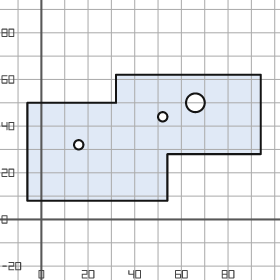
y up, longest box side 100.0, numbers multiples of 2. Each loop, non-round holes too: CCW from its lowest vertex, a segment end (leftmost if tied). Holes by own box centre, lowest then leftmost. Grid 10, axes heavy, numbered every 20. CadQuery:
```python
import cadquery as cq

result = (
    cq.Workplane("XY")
    .moveTo(-6.0, 8.0)
    .lineTo(54.0, 8.0)
    .lineTo(54.0, 28.0)
    .lineTo(94.0, 28.0)
    .lineTo(94.0, 62.0)
    .lineTo(32.0, 62.0)
    .lineTo(32.0, 50.0)
    .lineTo(-6.0, 50.0)
    .close()
    .moveTo(16.0, 32.0)
    .circle(2.0)
    .moveTo(52.0, 44.0)
    .circle(2.0)
    .moveTo(66.0, 50.0)
    .circle(4.0)
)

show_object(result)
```